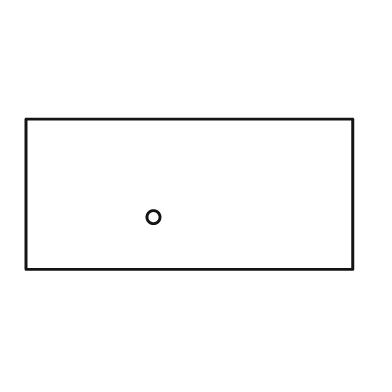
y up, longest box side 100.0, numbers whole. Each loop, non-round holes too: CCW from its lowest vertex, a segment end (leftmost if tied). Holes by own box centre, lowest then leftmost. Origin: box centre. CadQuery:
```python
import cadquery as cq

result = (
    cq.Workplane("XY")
    .moveTo(-50.0, -23.0)
    .lineTo(50.0, -23.0)
    .lineTo(50.0, 23.0)
    .lineTo(-50.0, 23.0)
    .close()
    .moveTo(-11.0, -7.0)
    .circle(2.0)
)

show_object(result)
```